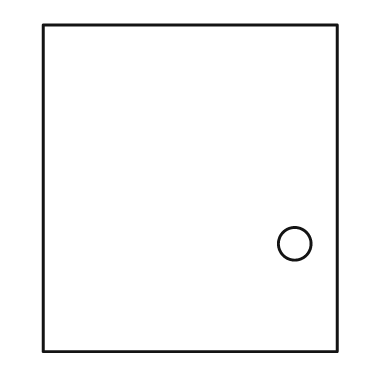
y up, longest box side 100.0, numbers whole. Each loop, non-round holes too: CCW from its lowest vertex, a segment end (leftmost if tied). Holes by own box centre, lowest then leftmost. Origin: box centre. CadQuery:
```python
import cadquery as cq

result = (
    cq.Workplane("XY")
    .moveTo(-45.0, -50.0)
    .lineTo(45.0, -50.0)
    .lineTo(45.0, 50.0)
    .lineTo(-45.0, 50.0)
    .close()
    .moveTo(32.0, -17.0)
    .circle(5.0)
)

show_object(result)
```